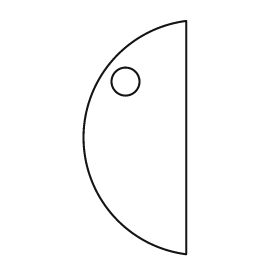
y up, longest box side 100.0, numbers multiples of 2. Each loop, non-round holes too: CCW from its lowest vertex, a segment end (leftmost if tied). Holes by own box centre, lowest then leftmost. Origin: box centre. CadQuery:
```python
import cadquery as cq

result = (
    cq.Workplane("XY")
    .moveTo(22.0, -50.0)
    .lineTo(22.0, 50.0)
    .threePointArc((-22.0, 0.0), (22.0, -50.0))
    .close()
    .moveTo(-4.0, 24.0)
    .circle(6.0)
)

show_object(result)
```